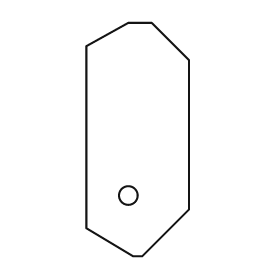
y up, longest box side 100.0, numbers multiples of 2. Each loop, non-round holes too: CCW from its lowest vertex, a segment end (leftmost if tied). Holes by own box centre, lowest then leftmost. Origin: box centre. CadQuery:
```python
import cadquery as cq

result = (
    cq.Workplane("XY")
    .moveTo(-2.0, -50.0)
    .lineTo(2.0, -50.0)
    .lineTo(22.0, -30.0)
    .lineTo(22.0, 34.0)
    .lineTo(6.0, 50.0)
    .lineTo(-4.0, 50.0)
    .lineTo(-22.0, 40.0)
    .lineTo(-22.0, -38.0)
    .close()
    .moveTo(-4.0, -24.0)
    .circle(4.0)
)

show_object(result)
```